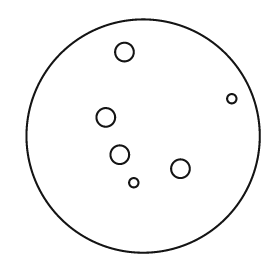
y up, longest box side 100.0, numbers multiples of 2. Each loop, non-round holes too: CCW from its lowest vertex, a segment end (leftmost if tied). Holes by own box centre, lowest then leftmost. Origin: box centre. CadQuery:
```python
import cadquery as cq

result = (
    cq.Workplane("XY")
    .moveTo(0.0, 0.0)
    .circle(50.0)
    .moveTo(-4.0, -20.0)
    .circle(2.0)
    .moveTo(16.0, -14.0)
    .circle(4.0)
    .moveTo(-10.0, -8.0)
    .circle(4.0)
    .moveTo(-16.0, 8.0)
    .circle(4.0)
    .moveTo(38.0, 16.0)
    .circle(2.0)
    .moveTo(-8.0, 36.0)
    .circle(4.0)
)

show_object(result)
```